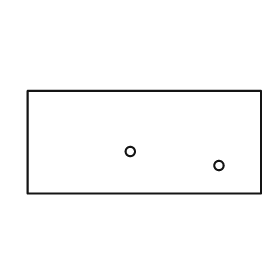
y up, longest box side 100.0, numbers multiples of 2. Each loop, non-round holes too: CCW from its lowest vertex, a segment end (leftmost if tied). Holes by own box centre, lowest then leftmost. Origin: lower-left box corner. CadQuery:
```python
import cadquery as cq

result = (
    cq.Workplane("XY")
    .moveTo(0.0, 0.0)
    .lineTo(100.0, 0.0)
    .lineTo(100.0, 44.0)
    .lineTo(0.0, 44.0)
    .close()
    .moveTo(82.0, 12.0)
    .circle(2.0)
    .moveTo(44.0, 18.0)
    .circle(2.0)
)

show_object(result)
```